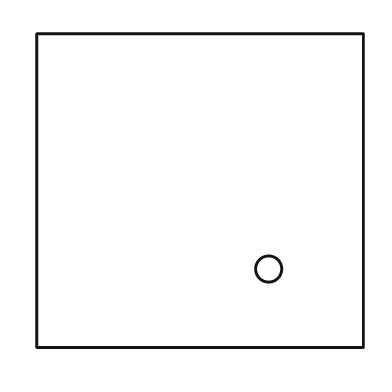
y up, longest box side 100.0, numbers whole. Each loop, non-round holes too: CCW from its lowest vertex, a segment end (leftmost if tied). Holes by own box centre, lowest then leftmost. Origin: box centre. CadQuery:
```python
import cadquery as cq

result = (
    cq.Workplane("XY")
    .moveTo(-50.0, -48.0)
    .lineTo(50.0, -48.0)
    .lineTo(50.0, 48.0)
    .lineTo(-50.0, 48.0)
    .close()
    .moveTo(21.0, -24.0)
    .circle(4.0)
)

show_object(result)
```